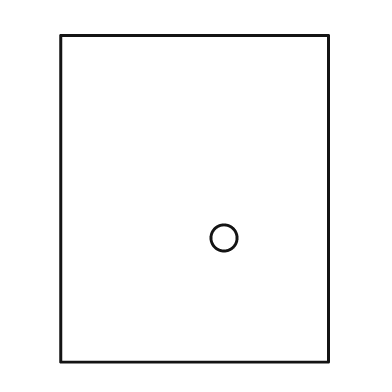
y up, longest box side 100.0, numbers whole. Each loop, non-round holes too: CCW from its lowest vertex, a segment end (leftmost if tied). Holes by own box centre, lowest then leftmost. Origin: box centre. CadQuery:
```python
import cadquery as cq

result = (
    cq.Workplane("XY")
    .moveTo(-41.0, -50.0)
    .lineTo(41.0, -50.0)
    .lineTo(41.0, 50.0)
    .lineTo(-41.0, 50.0)
    .close()
    .moveTo(9.0, -12.0)
    .circle(4.0)
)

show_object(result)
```